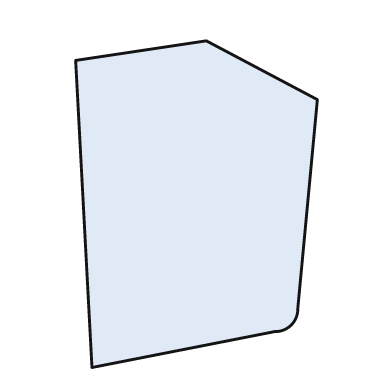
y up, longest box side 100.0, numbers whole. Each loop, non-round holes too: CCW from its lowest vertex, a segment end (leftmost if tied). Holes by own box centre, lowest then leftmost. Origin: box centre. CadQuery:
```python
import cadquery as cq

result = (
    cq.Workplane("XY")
    .moveTo(-32.0, -50.0)
    .lineTo(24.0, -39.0)
    .threePointArc((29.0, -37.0), (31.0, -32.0))
    .lineTo(37.0, 32.0)
    .lineTo(3.0, 50.0)
    .lineTo(-37.0, 44.0)
    .close()
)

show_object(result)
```